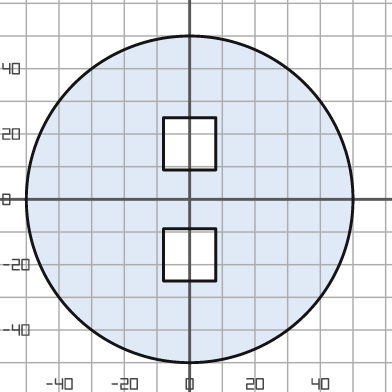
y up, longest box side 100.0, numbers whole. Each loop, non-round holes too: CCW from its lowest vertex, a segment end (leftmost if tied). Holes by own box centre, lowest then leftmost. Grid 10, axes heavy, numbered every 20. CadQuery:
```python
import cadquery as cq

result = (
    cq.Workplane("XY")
    .moveTo(0.0, 0.0)
    .circle(50.0)
    .moveTo(-8.0, -25.0)
    .lineTo(8.0, -25.0)
    .lineTo(8.0, -9.0)
    .lineTo(-8.0, -9.0)
    .close()
    .moveTo(-8.0, 9.0)
    .lineTo(8.0, 9.0)
    .lineTo(8.0, 25.0)
    .lineTo(-8.0, 25.0)
    .close()
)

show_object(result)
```